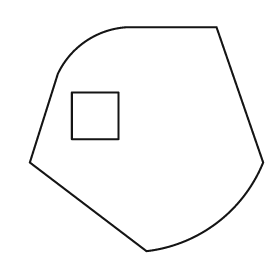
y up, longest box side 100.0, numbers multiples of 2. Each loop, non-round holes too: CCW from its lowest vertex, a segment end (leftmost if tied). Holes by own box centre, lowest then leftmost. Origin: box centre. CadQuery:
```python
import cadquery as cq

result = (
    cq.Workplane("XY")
    .moveTo(0.0, -48.0)
    .threePointArc((30.0, -36.0), (50.0, -10.0))
    .lineTo(30.0, 48.0)
    .lineTo(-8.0, 48.0)
    .threePointArc((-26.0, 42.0), (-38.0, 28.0))
    .lineTo(-50.0, -10.0)
    .close()
    .moveTo(-32.0, 0.0)
    .lineTo(-12.0, 0.0)
    .lineTo(-12.0, 20.0)
    .lineTo(-32.0, 20.0)
    .close()
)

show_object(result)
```